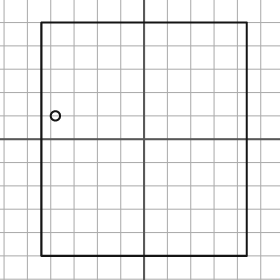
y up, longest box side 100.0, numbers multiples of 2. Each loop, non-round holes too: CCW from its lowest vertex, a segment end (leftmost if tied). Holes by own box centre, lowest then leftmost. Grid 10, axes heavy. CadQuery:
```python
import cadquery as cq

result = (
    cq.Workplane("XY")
    .moveTo(-44.0, -50.0)
    .lineTo(44.0, -50.0)
    .lineTo(44.0, 50.0)
    .lineTo(-44.0, 50.0)
    .close()
    .moveTo(-38.0, 10.0)
    .circle(2.0)
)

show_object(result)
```